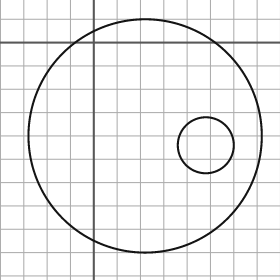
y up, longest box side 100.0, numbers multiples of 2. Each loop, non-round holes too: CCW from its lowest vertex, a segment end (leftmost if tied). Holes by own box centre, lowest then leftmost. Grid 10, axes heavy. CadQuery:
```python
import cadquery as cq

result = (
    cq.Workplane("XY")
    .moveTo(22.0, -40.0)
    .circle(50.0)
    .moveTo(48.0, -44.0)
    .circle(12.0)
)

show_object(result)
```